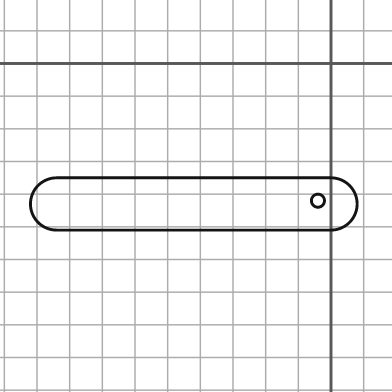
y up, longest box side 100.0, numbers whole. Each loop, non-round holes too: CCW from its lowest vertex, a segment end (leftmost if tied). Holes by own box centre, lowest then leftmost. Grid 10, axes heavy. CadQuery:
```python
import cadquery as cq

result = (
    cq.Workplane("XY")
    .moveTo(-84.0, -51.0)
    .lineTo(0.0, -51.0)
    .threePointArc((8.0, -43.0), (0.0, -35.0))
    .lineTo(-84.0, -35.0)
    .threePointArc((-92.0, -43.0), (-84.0, -51.0))
    .close()
    .moveTo(-4.0, -42.0)
    .circle(2.0)
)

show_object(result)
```